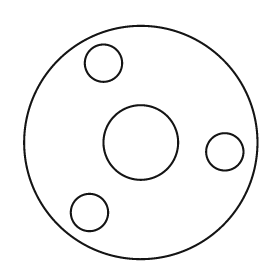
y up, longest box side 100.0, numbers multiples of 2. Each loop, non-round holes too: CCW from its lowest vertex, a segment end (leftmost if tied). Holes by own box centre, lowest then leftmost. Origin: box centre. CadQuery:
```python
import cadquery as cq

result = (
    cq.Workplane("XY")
    .moveTo(0.0, 0.0)
    .circle(50.0)
    .moveTo(-22.0, -30.0)
    .circle(8.0)
    .moveTo(36.0, -4.0)
    .circle(8.0)
    .moveTo(0.0, 0.0)
    .circle(16.0)
    .moveTo(-16.0, 34.0)
    .circle(8.0)
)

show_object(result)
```